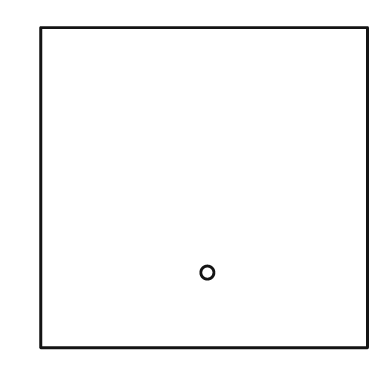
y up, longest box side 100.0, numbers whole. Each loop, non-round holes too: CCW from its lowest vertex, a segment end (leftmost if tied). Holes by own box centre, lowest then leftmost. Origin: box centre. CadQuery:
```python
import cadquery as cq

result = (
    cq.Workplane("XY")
    .moveTo(-50.0, -49.0)
    .lineTo(50.0, -49.0)
    .lineTo(50.0, 49.0)
    .lineTo(-50.0, 49.0)
    .close()
    .moveTo(1.0, -26.0)
    .circle(2.0)
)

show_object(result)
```